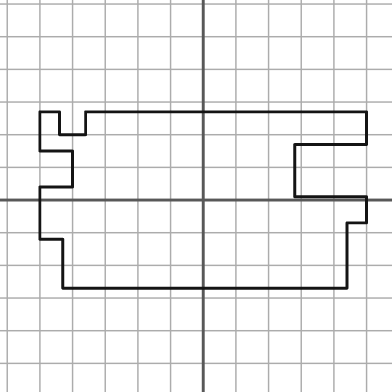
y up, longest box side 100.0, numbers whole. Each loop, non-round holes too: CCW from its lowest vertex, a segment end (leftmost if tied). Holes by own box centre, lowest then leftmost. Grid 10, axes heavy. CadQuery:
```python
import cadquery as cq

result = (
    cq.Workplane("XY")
    .moveTo(-43.0, -27.0)
    .lineTo(44.0, -27.0)
    .lineTo(44.0, -7.0)
    .lineTo(50.0, -7.0)
    .lineTo(50.0, 1.0)
    .lineTo(28.0, 1.0)
    .lineTo(28.0, 17.0)
    .lineTo(50.0, 17.0)
    .lineTo(50.0, 27.0)
    .lineTo(-36.0, 27.0)
    .lineTo(-36.0, 20.0)
    .lineTo(-44.0, 20.0)
    .lineTo(-44.0, 27.0)
    .lineTo(-50.0, 27.0)
    .lineTo(-50.0, 15.0)
    .lineTo(-40.0, 15.0)
    .lineTo(-40.0, 4.0)
    .lineTo(-50.0, 4.0)
    .lineTo(-50.0, -12.0)
    .lineTo(-43.0, -12.0)
    .close()
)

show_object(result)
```